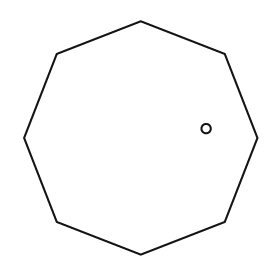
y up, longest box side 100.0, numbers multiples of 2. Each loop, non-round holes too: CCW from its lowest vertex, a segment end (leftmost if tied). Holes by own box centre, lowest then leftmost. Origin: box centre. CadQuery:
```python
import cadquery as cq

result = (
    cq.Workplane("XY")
    .moveTo(0.0, -50.0)
    .lineTo(36.0, -36.0)
    .lineTo(50.0, 0.0)
    .lineTo(36.0, 36.0)
    .lineTo(0.0, 50.0)
    .lineTo(-36.0, 36.0)
    .lineTo(-50.0, 0.0)
    .lineTo(-36.0, -36.0)
    .close()
    .moveTo(28.0, 4.0)
    .circle(2.0)
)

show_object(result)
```